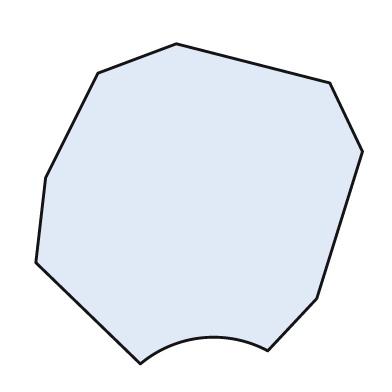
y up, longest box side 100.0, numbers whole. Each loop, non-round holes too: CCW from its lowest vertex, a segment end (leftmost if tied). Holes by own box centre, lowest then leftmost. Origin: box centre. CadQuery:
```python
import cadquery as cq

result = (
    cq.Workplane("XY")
    .moveTo(-18.0, -49.0)
    .threePointArc((1.0, -41.0), (21.0, -45.0))
    .lineTo(36.0, -29.0)
    .lineTo(50.0, 16.0)
    .lineTo(40.0, 37.0)
    .lineTo(-7.0, 49.0)
    .lineTo(-31.0, 40.0)
    .lineTo(-47.0, 8.0)
    .lineTo(-50.0, -18.0)
    .close()
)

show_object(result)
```